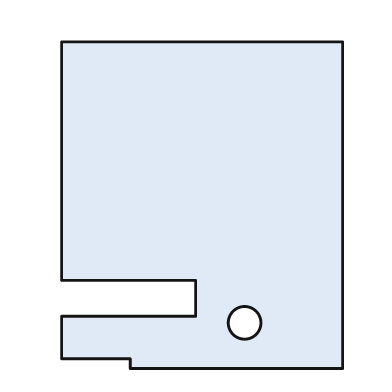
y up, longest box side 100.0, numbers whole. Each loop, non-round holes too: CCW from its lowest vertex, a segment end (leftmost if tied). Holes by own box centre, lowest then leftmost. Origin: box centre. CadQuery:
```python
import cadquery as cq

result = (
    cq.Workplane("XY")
    .moveTo(-22.0, -50.0)
    .lineTo(43.0, -50.0)
    .lineTo(43.0, 50.0)
    .lineTo(-43.0, 50.0)
    .lineTo(-43.0, -23.0)
    .lineTo(-2.0, -23.0)
    .lineTo(-2.0, -34.0)
    .lineTo(-43.0, -34.0)
    .lineTo(-43.0, -47.0)
    .lineTo(-22.0, -47.0)
    .close()
    .moveTo(13.0, -36.0)
    .circle(5.0)
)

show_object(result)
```